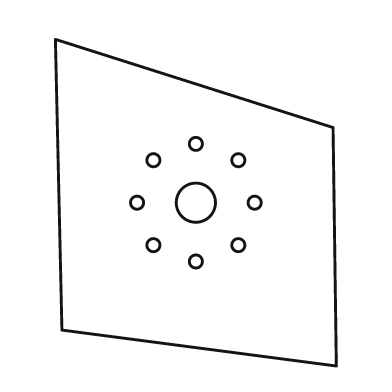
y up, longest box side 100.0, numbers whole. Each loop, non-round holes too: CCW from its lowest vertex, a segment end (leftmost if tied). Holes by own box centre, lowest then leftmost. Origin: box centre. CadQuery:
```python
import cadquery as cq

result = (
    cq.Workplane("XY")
    .moveTo(43.0, -50.0)
    .lineTo(42.0, 23.0)
    .lineTo(-43.0, 50.0)
    .lineTo(-41.0, -39.0)
    .close()
    .moveTo(0.0, -18.0)
    .circle(2.0)
    .moveTo(-13.0, -13.0)
    .circle(2.0)
    .moveTo(13.0, -13.0)
    .circle(2.0)
    .moveTo(-18.0, 0.0)
    .circle(2.0)
    .moveTo(0.0, 0.0)
    .circle(6.0)
    .moveTo(18.0, 0.0)
    .circle(2.0)
    .moveTo(-13.0, 13.0)
    .circle(2.0)
    .moveTo(13.0, 13.0)
    .circle(2.0)
    .moveTo(0.0, 18.0)
    .circle(2.0)
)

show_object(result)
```